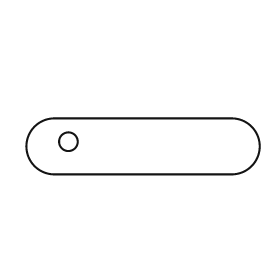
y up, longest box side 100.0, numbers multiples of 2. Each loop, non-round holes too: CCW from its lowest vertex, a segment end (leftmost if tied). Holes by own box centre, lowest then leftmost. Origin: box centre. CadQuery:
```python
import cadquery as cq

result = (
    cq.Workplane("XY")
    .moveTo(-38.0, -12.0)
    .lineTo(38.0, -12.0)
    .threePointArc((50.0, 0.0), (38.0, 12.0))
    .lineTo(-38.0, 12.0)
    .threePointArc((-50.0, 0.0), (-38.0, -12.0))
    .close()
    .moveTo(-32.0, 2.0)
    .circle(4.0)
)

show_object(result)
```